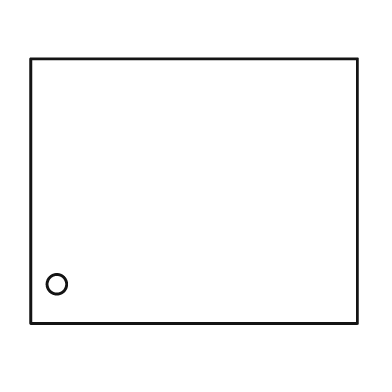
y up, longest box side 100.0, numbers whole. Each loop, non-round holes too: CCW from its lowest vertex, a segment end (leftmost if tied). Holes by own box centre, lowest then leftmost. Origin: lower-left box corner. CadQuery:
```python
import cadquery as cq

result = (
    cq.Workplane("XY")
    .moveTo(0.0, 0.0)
    .lineTo(100.0, 0.0)
    .lineTo(100.0, 81.0)
    .lineTo(0.0, 81.0)
    .close()
    .moveTo(8.0, 12.0)
    .circle(3.0)
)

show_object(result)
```